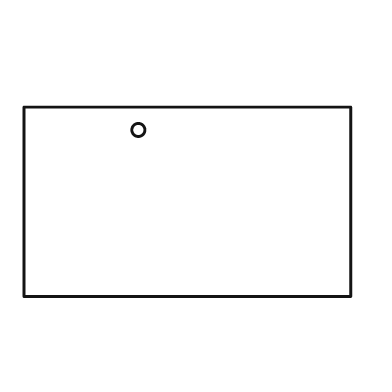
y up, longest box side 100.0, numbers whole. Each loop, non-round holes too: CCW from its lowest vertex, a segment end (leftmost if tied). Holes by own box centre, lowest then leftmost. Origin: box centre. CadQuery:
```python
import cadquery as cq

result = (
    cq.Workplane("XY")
    .moveTo(-50.0, -29.0)
    .lineTo(50.0, -29.0)
    .lineTo(50.0, 29.0)
    .lineTo(-50.0, 29.0)
    .close()
    .moveTo(-15.0, 22.0)
    .circle(2.0)
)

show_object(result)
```